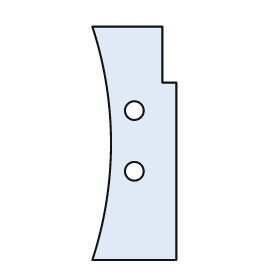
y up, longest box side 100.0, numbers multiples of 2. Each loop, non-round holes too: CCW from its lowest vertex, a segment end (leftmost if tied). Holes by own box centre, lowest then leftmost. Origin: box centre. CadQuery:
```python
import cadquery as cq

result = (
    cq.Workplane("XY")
    .moveTo(-18.0, -50.0)
    .lineTo(18.0, -50.0)
    .lineTo(18.0, 26.0)
    .lineTo(12.0, 26.0)
    .lineTo(12.0, 50.0)
    .lineTo(-18.0, 50.0)
    .threePointArc((-10.0, 0.0), (-18.0, -50.0))
    .close()
    .moveTo(0.0, -12.0)
    .circle(4.0)
    .moveTo(0.0, 14.0)
    .circle(4.0)
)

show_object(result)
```